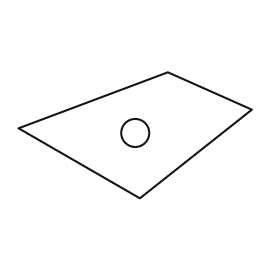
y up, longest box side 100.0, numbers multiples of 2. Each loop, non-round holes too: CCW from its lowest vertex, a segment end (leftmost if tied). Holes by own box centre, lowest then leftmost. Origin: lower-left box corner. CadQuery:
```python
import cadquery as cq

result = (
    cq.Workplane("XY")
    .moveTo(52.0, 0.0)
    .lineTo(100.0, 38.0)
    .lineTo(64.0, 54.0)
    .lineTo(0.0, 30.0)
    .close()
    .moveTo(50.0, 28.0)
    .circle(6.0)
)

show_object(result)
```